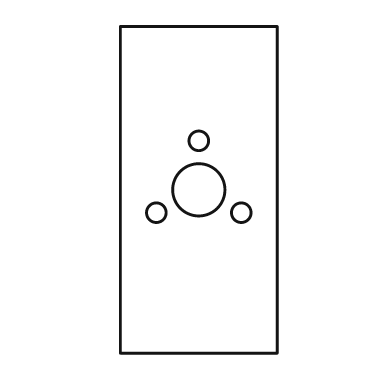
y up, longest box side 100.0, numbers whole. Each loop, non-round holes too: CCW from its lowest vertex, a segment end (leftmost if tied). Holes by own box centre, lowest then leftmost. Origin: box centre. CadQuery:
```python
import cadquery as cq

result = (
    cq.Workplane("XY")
    .moveTo(-24.0, -50.0)
    .lineTo(24.0, -50.0)
    .lineTo(24.0, 50.0)
    .lineTo(-24.0, 50.0)
    .close()
    .moveTo(-13.0, -7.0)
    .circle(3.0)
    .moveTo(13.0, -7.0)
    .circle(3.0)
    .moveTo(0.0, 0.0)
    .circle(8.0)
    .moveTo(0.0, 15.0)
    .circle(3.0)
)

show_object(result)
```